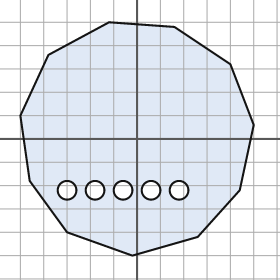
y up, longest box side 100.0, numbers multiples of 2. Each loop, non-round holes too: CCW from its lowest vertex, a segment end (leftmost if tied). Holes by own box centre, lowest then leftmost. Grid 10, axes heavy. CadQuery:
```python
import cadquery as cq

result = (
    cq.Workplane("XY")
    .moveTo(-2.0, -50.0)
    .lineTo(26.0, -42.0)
    .lineTo(44.0, -22.0)
    .lineTo(50.0, 6.0)
    .lineTo(40.0, 32.0)
    .lineTo(16.0, 48.0)
    .lineTo(-12.0, 50.0)
    .lineTo(-38.0, 36.0)
    .lineTo(-50.0, 10.0)
    .lineTo(-46.0, -18.0)
    .lineTo(-30.0, -40.0)
    .close()
    .moveTo(-30.0, -22.0)
    .circle(4.0)
    .moveTo(-18.0, -22.0)
    .circle(4.0)
    .moveTo(-6.0, -22.0)
    .circle(4.0)
    .moveTo(6.0, -22.0)
    .circle(4.0)
    .moveTo(18.0, -22.0)
    .circle(4.0)
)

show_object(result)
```